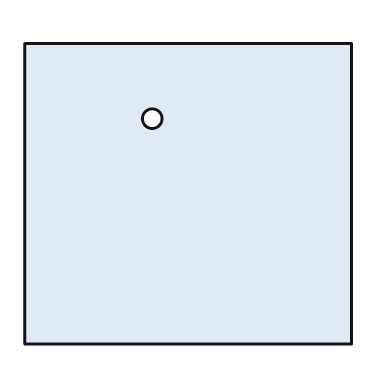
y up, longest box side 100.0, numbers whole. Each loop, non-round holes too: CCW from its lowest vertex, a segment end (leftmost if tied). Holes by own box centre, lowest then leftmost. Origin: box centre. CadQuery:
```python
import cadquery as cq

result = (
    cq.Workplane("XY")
    .moveTo(-50.0, -46.0)
    .lineTo(50.0, -46.0)
    .lineTo(50.0, 46.0)
    .lineTo(-50.0, 46.0)
    .close()
    .moveTo(-11.0, 23.0)
    .circle(3.0)
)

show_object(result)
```